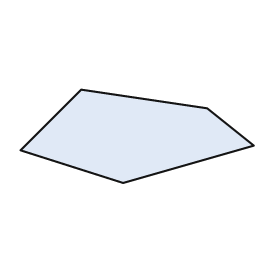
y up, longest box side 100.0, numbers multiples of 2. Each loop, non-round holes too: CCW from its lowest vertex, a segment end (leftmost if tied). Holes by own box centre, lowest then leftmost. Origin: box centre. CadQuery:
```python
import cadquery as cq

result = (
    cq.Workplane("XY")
    .moveTo(-6.0, -20.0)
    .lineTo(50.0, -4.0)
    .lineTo(30.0, 12.0)
    .lineTo(-24.0, 20.0)
    .lineTo(-50.0, -6.0)
    .close()
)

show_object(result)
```